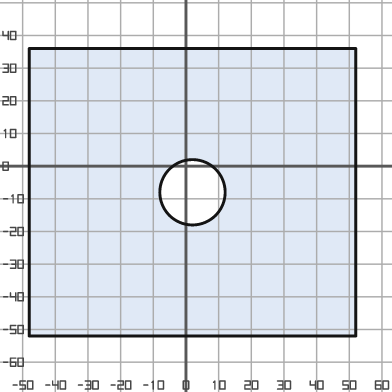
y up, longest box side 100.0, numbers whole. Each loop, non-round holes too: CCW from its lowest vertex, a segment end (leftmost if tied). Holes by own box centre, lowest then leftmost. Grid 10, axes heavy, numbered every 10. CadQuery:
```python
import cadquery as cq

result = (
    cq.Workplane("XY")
    .moveTo(-48.0, -52.0)
    .lineTo(52.0, -52.0)
    .lineTo(52.0, 36.0)
    .lineTo(-48.0, 36.0)
    .close()
    .moveTo(2.0, -8.0)
    .circle(10.0)
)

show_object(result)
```